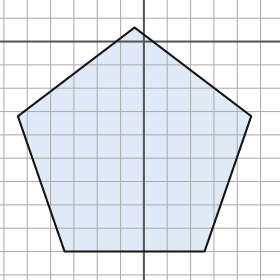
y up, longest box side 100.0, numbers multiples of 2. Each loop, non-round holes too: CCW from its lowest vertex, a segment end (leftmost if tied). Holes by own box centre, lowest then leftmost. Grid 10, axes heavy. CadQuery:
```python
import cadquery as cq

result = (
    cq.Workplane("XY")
    .moveTo(-34.0, -90.0)
    .lineTo(26.0, -90.0)
    .lineTo(46.0, -32.0)
    .lineTo(-4.0, 6.0)
    .lineTo(-54.0, -32.0)
    .close()
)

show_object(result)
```